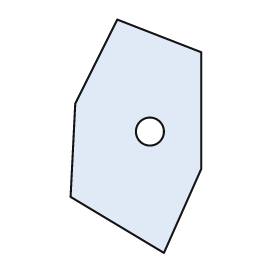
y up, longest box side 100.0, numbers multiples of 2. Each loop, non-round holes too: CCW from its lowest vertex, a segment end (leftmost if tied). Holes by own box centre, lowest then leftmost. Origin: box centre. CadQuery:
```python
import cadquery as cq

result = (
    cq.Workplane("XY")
    .moveTo(12.0, -50.0)
    .lineTo(28.0, -14.0)
    .lineTo(28.0, 36.0)
    .lineTo(-8.0, 50.0)
    .lineTo(-26.0, 14.0)
    .lineTo(-28.0, -26.0)
    .close()
    .moveTo(6.0, 2.0)
    .circle(6.0)
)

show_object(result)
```